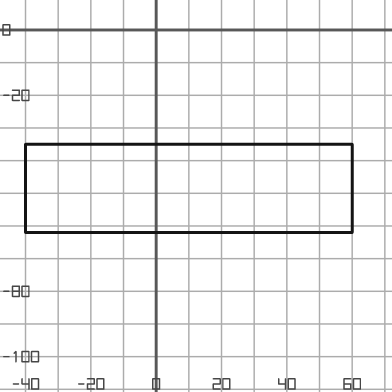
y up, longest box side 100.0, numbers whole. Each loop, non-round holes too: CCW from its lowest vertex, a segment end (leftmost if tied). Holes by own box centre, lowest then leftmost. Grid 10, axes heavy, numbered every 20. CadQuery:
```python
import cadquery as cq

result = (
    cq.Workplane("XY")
    .moveTo(-40.0, -62.0)
    .lineTo(60.0, -62.0)
    .lineTo(60.0, -35.0)
    .lineTo(-40.0, -35.0)
    .close()
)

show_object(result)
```